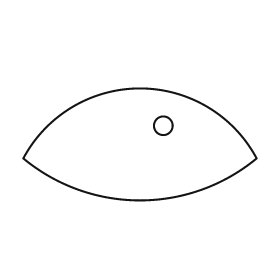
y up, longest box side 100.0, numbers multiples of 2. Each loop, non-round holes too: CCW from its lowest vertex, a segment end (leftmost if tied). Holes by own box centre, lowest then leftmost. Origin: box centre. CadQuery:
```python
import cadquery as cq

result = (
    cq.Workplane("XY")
    .moveTo(-50.0, -6.0)
    .threePointArc((0.0, -24.0), (50.0, -6.0))
    .threePointArc((0.0, 24.0), (-50.0, -6.0))
    .close()
    .moveTo(10.0, 8.0)
    .circle(4.0)
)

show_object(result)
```